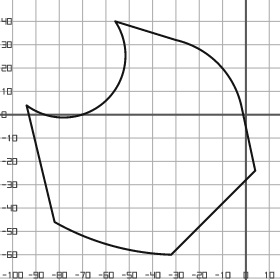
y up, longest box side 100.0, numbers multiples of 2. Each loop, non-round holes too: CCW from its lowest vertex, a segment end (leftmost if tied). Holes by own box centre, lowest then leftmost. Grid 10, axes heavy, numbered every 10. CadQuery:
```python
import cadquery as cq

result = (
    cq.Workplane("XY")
    .moveTo(-32.0, -60.0)
    .lineTo(4.0, -24.0)
    .lineTo(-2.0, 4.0)
    .threePointArc((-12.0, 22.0), (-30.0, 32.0))
    .lineTo(-56.0, 40.0)
    .threePointArc((-60.0, 6.0), (-94.0, 4.0))
    .lineTo(-82.0, -46.0)
    .threePointArc((-58.0, -56.0), (-32.0, -60.0))
    .close()
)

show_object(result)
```